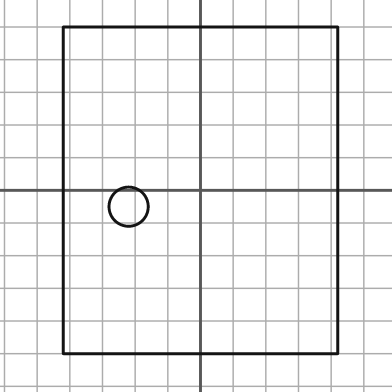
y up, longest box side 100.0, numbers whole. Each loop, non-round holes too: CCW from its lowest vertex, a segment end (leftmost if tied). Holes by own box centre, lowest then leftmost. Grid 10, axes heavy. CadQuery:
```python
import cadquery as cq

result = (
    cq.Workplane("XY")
    .moveTo(-42.0, -50.0)
    .lineTo(42.0, -50.0)
    .lineTo(42.0, 50.0)
    .lineTo(-42.0, 50.0)
    .close()
    .moveTo(-22.0, -5.0)
    .circle(6.0)
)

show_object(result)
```